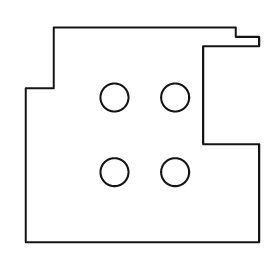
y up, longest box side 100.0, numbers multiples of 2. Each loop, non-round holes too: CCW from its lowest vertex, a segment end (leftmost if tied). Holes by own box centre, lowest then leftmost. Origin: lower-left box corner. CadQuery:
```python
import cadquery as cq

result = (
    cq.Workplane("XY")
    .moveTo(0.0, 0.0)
    .lineTo(100.0, 0.0)
    .lineTo(100.0, 42.0)
    .lineTo(76.0, 42.0)
    .lineTo(76.0, 84.0)
    .lineTo(100.0, 84.0)
    .lineTo(100.0, 88.0)
    .lineTo(90.0, 88.0)
    .lineTo(90.0, 92.0)
    .lineTo(12.0, 92.0)
    .lineTo(12.0, 66.0)
    .lineTo(0.0, 66.0)
    .close()
    .moveTo(38.0, 30.0)
    .circle(6.0)
    .moveTo(64.0, 30.0)
    .circle(6.0)
    .moveTo(38.0, 62.0)
    .circle(6.0)
    .moveTo(64.0, 62.0)
    .circle(6.0)
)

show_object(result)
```